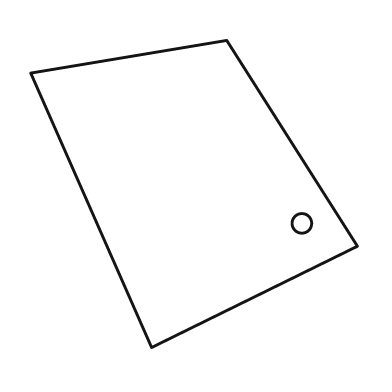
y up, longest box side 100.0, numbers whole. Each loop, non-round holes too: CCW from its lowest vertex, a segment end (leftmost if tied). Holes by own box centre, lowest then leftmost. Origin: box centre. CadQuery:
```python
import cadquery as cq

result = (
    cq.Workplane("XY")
    .moveTo(-13.0, -47.0)
    .lineTo(50.0, -16.0)
    .lineTo(10.0, 47.0)
    .lineTo(-50.0, 37.0)
    .close()
    .moveTo(33.0, -9.0)
    .circle(3.0)
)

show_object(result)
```